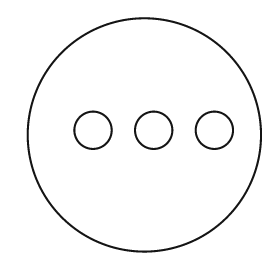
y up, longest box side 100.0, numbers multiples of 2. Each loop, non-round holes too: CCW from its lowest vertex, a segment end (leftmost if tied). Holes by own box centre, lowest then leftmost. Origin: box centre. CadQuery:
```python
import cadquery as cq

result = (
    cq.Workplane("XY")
    .moveTo(0.0, 0.0)
    .circle(50.0)
    .moveTo(-22.0, 2.0)
    .circle(8.0)
    .moveTo(4.0, 2.0)
    .circle(8.0)
    .moveTo(30.0, 2.0)
    .circle(8.0)
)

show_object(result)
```